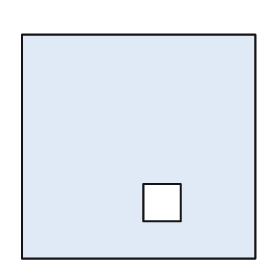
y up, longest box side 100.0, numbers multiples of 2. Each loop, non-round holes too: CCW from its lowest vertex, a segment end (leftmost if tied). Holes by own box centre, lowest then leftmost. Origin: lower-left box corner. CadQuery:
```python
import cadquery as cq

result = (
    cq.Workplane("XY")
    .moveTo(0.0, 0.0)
    .lineTo(100.0, 0.0)
    .lineTo(100.0, 96.0)
    .lineTo(0.0, 96.0)
    .close()
    .moveTo(52.0, 16.0)
    .lineTo(68.0, 16.0)
    .lineTo(68.0, 32.0)
    .lineTo(52.0, 32.0)
    .close()
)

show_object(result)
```